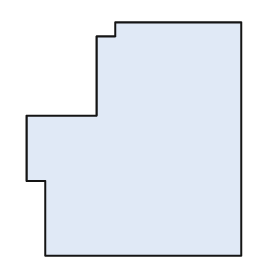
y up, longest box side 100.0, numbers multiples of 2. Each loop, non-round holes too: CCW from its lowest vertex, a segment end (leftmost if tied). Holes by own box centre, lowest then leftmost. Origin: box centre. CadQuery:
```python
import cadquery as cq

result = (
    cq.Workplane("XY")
    .moveTo(-38.0, -50.0)
    .lineTo(46.0, -50.0)
    .lineTo(46.0, 50.0)
    .lineTo(-8.0, 50.0)
    .lineTo(-8.0, 44.0)
    .lineTo(-16.0, 44.0)
    .lineTo(-16.0, 10.0)
    .lineTo(-46.0, 10.0)
    .lineTo(-46.0, -18.0)
    .lineTo(-38.0, -18.0)
    .close()
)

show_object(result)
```